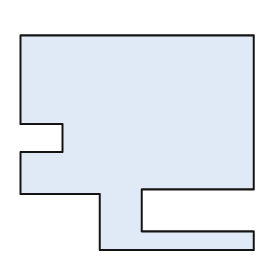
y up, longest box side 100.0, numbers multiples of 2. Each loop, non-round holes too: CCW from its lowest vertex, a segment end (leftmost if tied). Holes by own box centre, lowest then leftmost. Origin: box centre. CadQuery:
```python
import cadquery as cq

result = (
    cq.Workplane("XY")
    .moveTo(-16.0, -46.0)
    .lineTo(50.0, -46.0)
    .lineTo(50.0, -38.0)
    .lineTo(2.0, -38.0)
    .lineTo(2.0, -20.0)
    .lineTo(50.0, -20.0)
    .lineTo(50.0, 46.0)
    .lineTo(-50.0, 46.0)
    .lineTo(-50.0, 8.0)
    .lineTo(-32.0, 8.0)
    .lineTo(-32.0, -4.0)
    .lineTo(-50.0, -4.0)
    .lineTo(-50.0, -22.0)
    .lineTo(-16.0, -22.0)
    .close()
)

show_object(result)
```